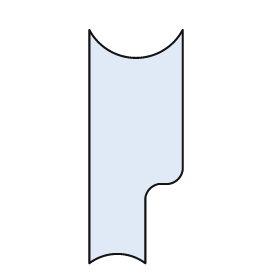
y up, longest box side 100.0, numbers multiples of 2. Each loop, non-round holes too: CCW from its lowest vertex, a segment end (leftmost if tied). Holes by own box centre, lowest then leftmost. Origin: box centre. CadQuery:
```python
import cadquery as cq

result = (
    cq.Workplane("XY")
    .moveTo(-20.0, -50.0)
    .threePointArc((-8.0, -46.0), (4.0, -50.0))
    .lineTo(4.0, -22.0)
    .threePointArc((6.0, -18.0), (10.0, -16.0))
    .lineTo(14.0, -16.0)
    .threePointArc((18.0, -14.0), (20.0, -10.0))
    .lineTo(20.0, 50.0)
    .threePointArc((0.0, 38.0), (-20.0, 50.0))
    .close()
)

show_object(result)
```